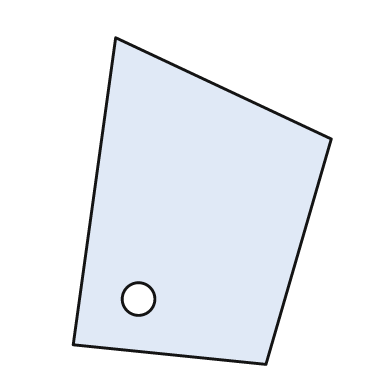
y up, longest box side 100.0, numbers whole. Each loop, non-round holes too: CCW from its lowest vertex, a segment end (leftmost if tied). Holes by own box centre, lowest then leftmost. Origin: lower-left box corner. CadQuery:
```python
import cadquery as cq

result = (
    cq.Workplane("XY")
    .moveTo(59.0, 0.0)
    .lineTo(79.0, 69.0)
    .lineTo(13.0, 100.0)
    .lineTo(0.0, 6.0)
    .close()
    .moveTo(20.0, 20.0)
    .circle(5.0)
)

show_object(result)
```